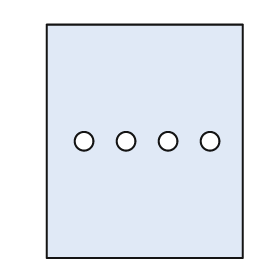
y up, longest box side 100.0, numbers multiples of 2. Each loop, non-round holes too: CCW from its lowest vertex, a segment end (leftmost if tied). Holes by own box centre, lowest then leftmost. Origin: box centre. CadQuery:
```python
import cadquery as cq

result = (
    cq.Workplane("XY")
    .moveTo(-42.0, -50.0)
    .lineTo(42.0, -50.0)
    .lineTo(42.0, 50.0)
    .lineTo(-42.0, 50.0)
    .close()
    .moveTo(-26.0, 0.0)
    .circle(4.0)
    .moveTo(-8.0, 0.0)
    .circle(4.0)
    .moveTo(10.0, 0.0)
    .circle(4.0)
    .moveTo(28.0, 0.0)
    .circle(4.0)
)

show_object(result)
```